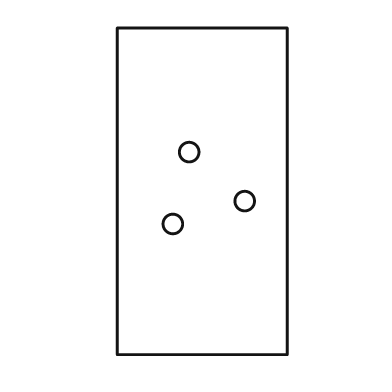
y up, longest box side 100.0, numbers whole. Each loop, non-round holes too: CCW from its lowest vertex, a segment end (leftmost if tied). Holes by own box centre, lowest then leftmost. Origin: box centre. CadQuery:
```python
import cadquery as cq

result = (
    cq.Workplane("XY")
    .moveTo(-26.0, -50.0)
    .lineTo(26.0, -50.0)
    .lineTo(26.0, 50.0)
    .lineTo(-26.0, 50.0)
    .close()
    .moveTo(-9.0, -10.0)
    .circle(3.0)
    .moveTo(13.0, -3.0)
    .circle(3.0)
    .moveTo(-4.0, 12.0)
    .circle(3.0)
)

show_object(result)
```